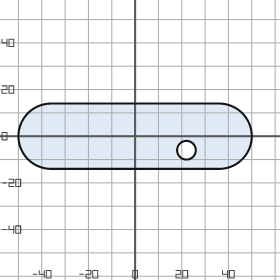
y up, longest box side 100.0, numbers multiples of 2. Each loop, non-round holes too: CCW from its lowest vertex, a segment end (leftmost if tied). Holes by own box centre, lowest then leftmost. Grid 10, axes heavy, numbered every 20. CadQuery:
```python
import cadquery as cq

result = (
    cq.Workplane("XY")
    .moveTo(-36.0, -14.0)
    .lineTo(36.0, -14.0)
    .threePointArc((50.0, 0.0), (36.0, 14.0))
    .lineTo(-36.0, 14.0)
    .threePointArc((-50.0, 0.0), (-36.0, -14.0))
    .close()
    .moveTo(22.0, -6.0)
    .circle(4.0)
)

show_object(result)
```